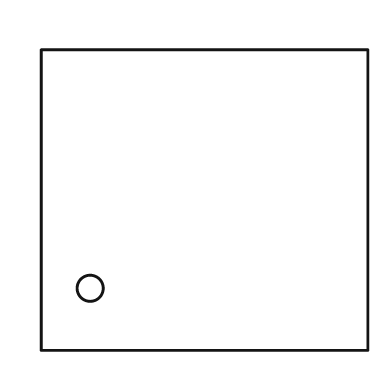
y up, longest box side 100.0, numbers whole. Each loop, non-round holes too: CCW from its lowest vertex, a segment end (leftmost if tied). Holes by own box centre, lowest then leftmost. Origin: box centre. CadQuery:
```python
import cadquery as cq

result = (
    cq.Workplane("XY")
    .moveTo(-50.0, -46.0)
    .lineTo(50.0, -46.0)
    .lineTo(50.0, 46.0)
    .lineTo(-50.0, 46.0)
    .close()
    .moveTo(-35.0, -27.0)
    .circle(4.0)
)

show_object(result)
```